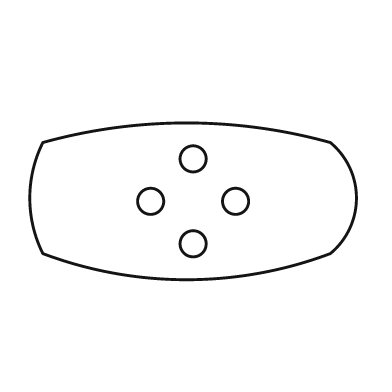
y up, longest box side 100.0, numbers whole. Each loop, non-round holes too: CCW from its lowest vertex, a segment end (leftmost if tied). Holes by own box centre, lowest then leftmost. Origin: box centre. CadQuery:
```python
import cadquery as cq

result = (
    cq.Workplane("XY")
    .moveTo(-46.0, -16.0)
    .threePointArc((-2.0, -24.0), (42.0, -16.0))
    .threePointArc((50.0, 1.0), (42.0, 18.0))
    .threePointArc((-2.0, 24.0), (-46.0, 18.0))
    .threePointArc((-50.0, 1.0), (-46.0, -16.0))
    .close()
    .moveTo(0.0, -13.0)
    .circle(4.0)
    .moveTo(-13.0, 0.0)
    .circle(4.0)
    .moveTo(13.0, 0.0)
    .circle(4.0)
    .moveTo(0.0, 13.0)
    .circle(4.0)
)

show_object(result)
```